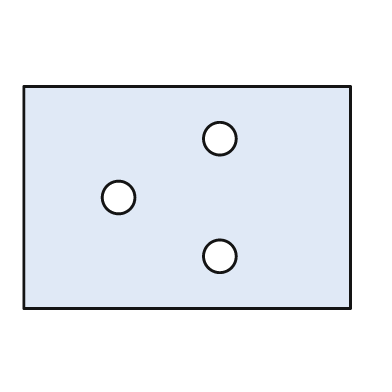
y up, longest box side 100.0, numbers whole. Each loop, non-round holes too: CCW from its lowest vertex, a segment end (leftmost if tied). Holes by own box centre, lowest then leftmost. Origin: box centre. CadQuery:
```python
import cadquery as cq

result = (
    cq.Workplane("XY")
    .moveTo(-50.0, -34.0)
    .lineTo(50.0, -34.0)
    .lineTo(50.0, 34.0)
    .lineTo(-50.0, 34.0)
    .close()
    .moveTo(10.0, -18.0)
    .circle(5.0)
    .moveTo(-21.0, 0.0)
    .circle(5.0)
    .moveTo(10.0, 18.0)
    .circle(5.0)
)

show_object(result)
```